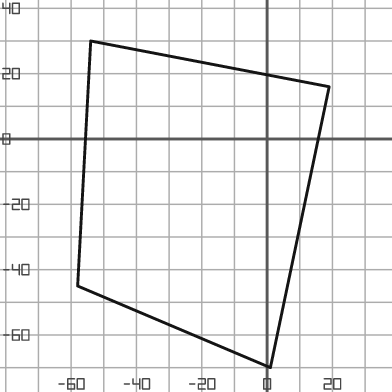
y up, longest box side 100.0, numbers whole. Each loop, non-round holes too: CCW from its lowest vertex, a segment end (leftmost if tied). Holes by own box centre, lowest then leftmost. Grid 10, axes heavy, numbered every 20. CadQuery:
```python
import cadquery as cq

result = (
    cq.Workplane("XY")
    .moveTo(1.0, -70.0)
    .lineTo(19.0, 16.0)
    .lineTo(-54.0, 30.0)
    .lineTo(-58.0, -45.0)
    .close()
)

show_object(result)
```